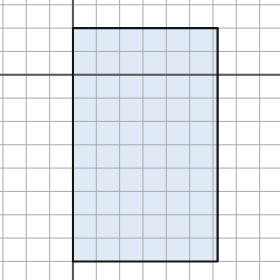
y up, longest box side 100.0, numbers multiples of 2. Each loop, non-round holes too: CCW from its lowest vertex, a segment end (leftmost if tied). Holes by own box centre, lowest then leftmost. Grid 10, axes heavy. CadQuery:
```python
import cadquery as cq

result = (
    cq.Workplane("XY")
    .moveTo(0.0, -80.0)
    .lineTo(62.0, -80.0)
    .lineTo(62.0, 20.0)
    .lineTo(0.0, 20.0)
    .close()
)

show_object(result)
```